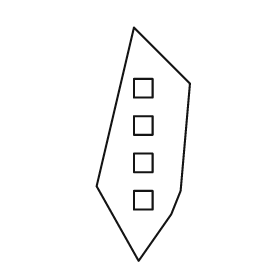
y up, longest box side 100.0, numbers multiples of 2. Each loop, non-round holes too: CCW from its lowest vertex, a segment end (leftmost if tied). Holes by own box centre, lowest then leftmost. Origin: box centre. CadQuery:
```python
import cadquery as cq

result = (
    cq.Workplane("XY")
    .moveTo(-2.0, -50.0)
    .lineTo(12.0, -30.0)
    .lineTo(16.0, -20.0)
    .lineTo(20.0, 26.0)
    .lineTo(-4.0, 50.0)
    .lineTo(-20.0, -18.0)
    .close()
    .moveTo(-4.0, -28.0)
    .lineTo(4.0, -28.0)
    .lineTo(4.0, -20.0)
    .lineTo(-4.0, -20.0)
    .close()
    .moveTo(-4.0, -12.0)
    .lineTo(4.0, -12.0)
    .lineTo(4.0, -4.0)
    .lineTo(-4.0, -4.0)
    .close()
    .moveTo(-4.0, 4.0)
    .lineTo(4.0, 4.0)
    .lineTo(4.0, 12.0)
    .lineTo(-4.0, 12.0)
    .close()
    .moveTo(-4.0, 20.0)
    .lineTo(4.0, 20.0)
    .lineTo(4.0, 28.0)
    .lineTo(-4.0, 28.0)
    .close()
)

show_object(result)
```